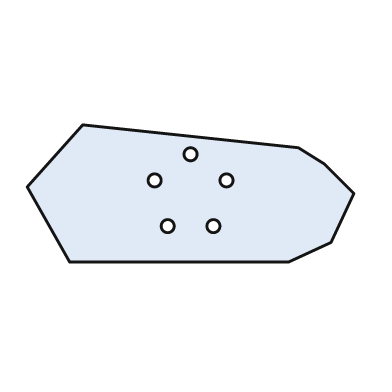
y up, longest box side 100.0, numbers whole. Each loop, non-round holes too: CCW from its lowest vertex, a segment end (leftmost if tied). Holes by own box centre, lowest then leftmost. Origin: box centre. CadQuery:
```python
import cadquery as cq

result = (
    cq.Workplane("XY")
    .moveTo(-37.0, -21.0)
    .lineTo(30.0, -21.0)
    .lineTo(43.0, -15.0)
    .lineTo(50.0, 0.0)
    .lineTo(41.0, 9.0)
    .lineTo(33.0, 14.0)
    .lineTo(-33.0, 21.0)
    .lineTo(-50.0, 2.0)
    .close()
    .moveTo(-7.0, -10.0)
    .circle(2.0)
    .moveTo(7.0, -10.0)
    .circle(2.0)
    .moveTo(-11.0, 4.0)
    .circle(2.0)
    .moveTo(11.0, 4.0)
    .circle(2.0)
    .moveTo(0.0, 12.0)
    .circle(2.0)
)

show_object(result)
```